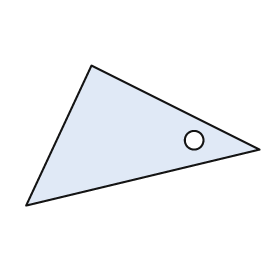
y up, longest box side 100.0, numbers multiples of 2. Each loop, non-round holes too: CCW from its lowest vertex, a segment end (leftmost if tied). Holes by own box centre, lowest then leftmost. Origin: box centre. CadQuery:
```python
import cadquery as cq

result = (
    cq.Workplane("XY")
    .moveTo(-50.0, -30.0)
    .lineTo(50.0, -6.0)
    .lineTo(-22.0, 30.0)
    .close()
    .moveTo(22.0, -2.0)
    .circle(4.0)
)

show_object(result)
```